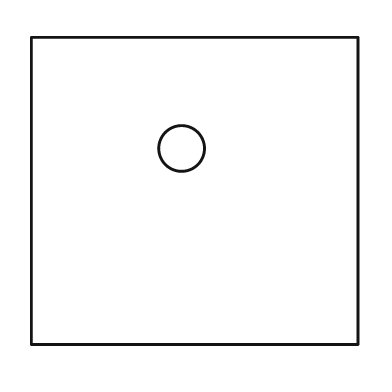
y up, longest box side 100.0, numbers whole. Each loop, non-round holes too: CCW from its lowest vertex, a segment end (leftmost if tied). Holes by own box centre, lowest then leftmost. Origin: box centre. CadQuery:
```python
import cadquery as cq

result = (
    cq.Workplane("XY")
    .moveTo(-50.0, -47.0)
    .lineTo(50.0, -47.0)
    .lineTo(50.0, 47.0)
    .lineTo(-50.0, 47.0)
    .close()
    .moveTo(-4.0, 13.0)
    .circle(7.0)
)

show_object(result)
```